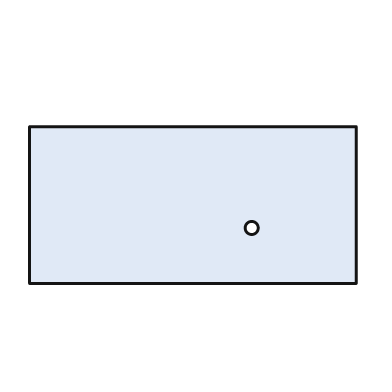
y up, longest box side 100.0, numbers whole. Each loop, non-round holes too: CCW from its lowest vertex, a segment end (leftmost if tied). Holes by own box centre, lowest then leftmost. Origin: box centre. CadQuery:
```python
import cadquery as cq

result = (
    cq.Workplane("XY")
    .moveTo(-50.0, -24.0)
    .lineTo(50.0, -24.0)
    .lineTo(50.0, 24.0)
    .lineTo(-50.0, 24.0)
    .close()
    .moveTo(18.0, -7.0)
    .circle(2.0)
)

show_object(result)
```